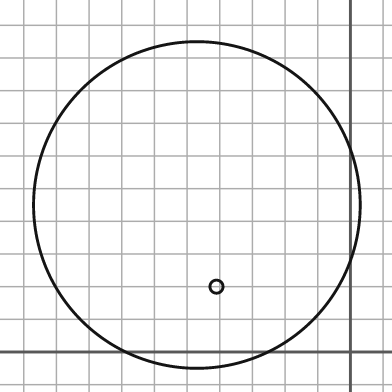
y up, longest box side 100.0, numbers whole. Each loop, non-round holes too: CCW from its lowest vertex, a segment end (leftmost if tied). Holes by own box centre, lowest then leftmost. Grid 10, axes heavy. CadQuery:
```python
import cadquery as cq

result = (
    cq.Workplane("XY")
    .moveTo(-47.0, 45.0)
    .circle(50.0)
    .moveTo(-41.0, 20.0)
    .circle(2.0)
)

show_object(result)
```